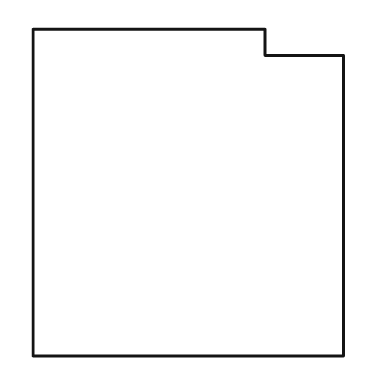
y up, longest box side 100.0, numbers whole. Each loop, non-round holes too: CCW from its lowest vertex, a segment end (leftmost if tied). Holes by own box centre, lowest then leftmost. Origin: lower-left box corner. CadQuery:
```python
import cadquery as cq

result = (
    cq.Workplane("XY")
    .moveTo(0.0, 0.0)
    .lineTo(95.0, 0.0)
    .lineTo(95.0, 92.0)
    .lineTo(71.0, 92.0)
    .lineTo(71.0, 100.0)
    .lineTo(0.0, 100.0)
    .close()
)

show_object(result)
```